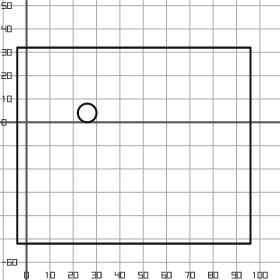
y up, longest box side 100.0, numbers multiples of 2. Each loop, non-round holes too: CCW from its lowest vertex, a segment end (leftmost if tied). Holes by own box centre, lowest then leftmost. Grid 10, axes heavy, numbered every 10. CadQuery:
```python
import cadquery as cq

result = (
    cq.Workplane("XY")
    .moveTo(-4.0, -52.0)
    .lineTo(96.0, -52.0)
    .lineTo(96.0, 32.0)
    .lineTo(-4.0, 32.0)
    .close()
    .moveTo(26.0, 4.0)
    .circle(4.0)
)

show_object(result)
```